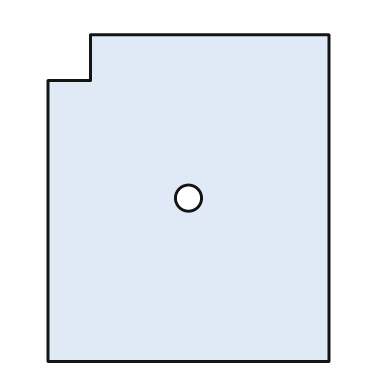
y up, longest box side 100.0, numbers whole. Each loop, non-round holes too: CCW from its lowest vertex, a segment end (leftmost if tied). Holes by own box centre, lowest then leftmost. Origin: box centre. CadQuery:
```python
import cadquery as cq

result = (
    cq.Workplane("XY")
    .moveTo(-43.0, -50.0)
    .lineTo(43.0, -50.0)
    .lineTo(43.0, 50.0)
    .lineTo(-30.0, 50.0)
    .lineTo(-30.0, 36.0)
    .lineTo(-43.0, 36.0)
    .close()
    .moveTo(0.0, 0.0)
    .circle(4.0)
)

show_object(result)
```